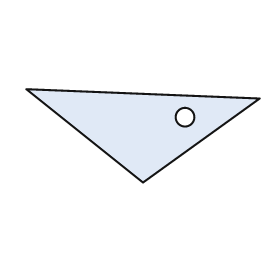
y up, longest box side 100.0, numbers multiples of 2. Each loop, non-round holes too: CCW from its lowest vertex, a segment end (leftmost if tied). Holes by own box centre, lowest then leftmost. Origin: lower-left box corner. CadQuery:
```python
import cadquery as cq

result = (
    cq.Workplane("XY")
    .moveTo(50.0, 0.0)
    .lineTo(100.0, 36.0)
    .lineTo(0.0, 40.0)
    .close()
    .moveTo(68.0, 28.0)
    .circle(4.0)
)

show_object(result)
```